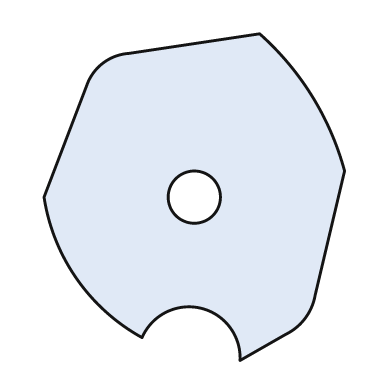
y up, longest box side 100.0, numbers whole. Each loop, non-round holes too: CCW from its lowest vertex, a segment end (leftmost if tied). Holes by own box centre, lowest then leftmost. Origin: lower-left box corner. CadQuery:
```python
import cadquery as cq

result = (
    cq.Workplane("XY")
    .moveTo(60.0, 0.0)
    .lineTo(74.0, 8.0)
    .threePointArc((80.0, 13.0), (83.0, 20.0))
    .lineTo(92.0, 58.0)
    .threePointArc((82.0, 81.0), (66.0, 100.0))
    .lineTo(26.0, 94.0)
    .threePointArc((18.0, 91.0), (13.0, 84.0))
    .lineTo(0.0, 50.0)
    .threePointArc((10.0, 25.0), (30.0, 7.0))
    .threePointArc((48.0, 16.0), (60.0, 0.0))
    .close()
    .moveTo(46.0, 50.0)
    .circle(8.0)
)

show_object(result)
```